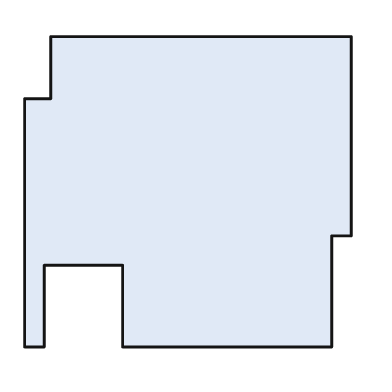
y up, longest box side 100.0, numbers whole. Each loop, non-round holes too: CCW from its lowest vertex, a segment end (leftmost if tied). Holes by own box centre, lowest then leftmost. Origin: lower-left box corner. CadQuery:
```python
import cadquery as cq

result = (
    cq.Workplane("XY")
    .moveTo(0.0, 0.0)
    .lineTo(6.0, 0.0)
    .lineTo(6.0, 25.0)
    .lineTo(30.0, 25.0)
    .lineTo(30.0, 0.0)
    .lineTo(94.0, 0.0)
    .lineTo(94.0, 34.0)
    .lineTo(100.0, 34.0)
    .lineTo(100.0, 95.0)
    .lineTo(8.0, 95.0)
    .lineTo(8.0, 76.0)
    .lineTo(0.0, 76.0)
    .close()
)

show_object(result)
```